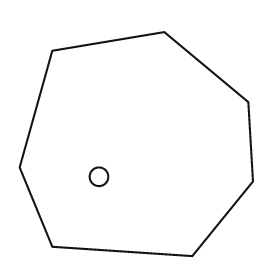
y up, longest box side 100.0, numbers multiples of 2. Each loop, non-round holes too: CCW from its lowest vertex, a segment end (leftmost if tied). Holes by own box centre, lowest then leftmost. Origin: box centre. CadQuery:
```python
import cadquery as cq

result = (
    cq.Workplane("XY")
    .moveTo(24.0, -48.0)
    .lineTo(50.0, -16.0)
    .lineTo(48.0, 18.0)
    .lineTo(12.0, 48.0)
    .lineTo(-36.0, 40.0)
    .lineTo(-50.0, -10.0)
    .lineTo(-36.0, -44.0)
    .close()
    .moveTo(-16.0, -14.0)
    .circle(4.0)
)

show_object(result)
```